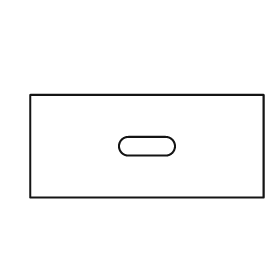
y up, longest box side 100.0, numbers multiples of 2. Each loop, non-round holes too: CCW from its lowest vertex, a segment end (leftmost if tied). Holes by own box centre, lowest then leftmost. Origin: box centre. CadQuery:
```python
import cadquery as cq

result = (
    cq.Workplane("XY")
    .moveTo(-50.0, -22.0)
    .lineTo(50.0, -22.0)
    .lineTo(50.0, 22.0)
    .lineTo(-50.0, 22.0)
    .close()
    .moveTo(-8.0, -4.0)
    .lineTo(8.0, -4.0)
    .threePointArc((12.0, 0.0), (8.0, 4.0))
    .lineTo(-8.0, 4.0)
    .threePointArc((-12.0, 0.0), (-8.0, -4.0))
    .close()
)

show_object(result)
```